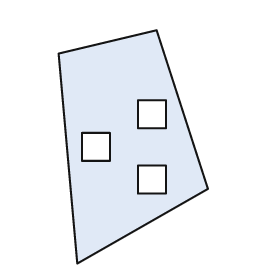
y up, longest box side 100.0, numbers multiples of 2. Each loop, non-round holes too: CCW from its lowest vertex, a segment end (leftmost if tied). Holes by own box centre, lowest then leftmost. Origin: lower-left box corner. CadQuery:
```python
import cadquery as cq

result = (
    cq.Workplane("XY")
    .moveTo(8.0, 0.0)
    .lineTo(64.0, 32.0)
    .lineTo(42.0, 100.0)
    .lineTo(0.0, 90.0)
    .close()
    .moveTo(34.0, 30.0)
    .lineTo(46.0, 30.0)
    .lineTo(46.0, 42.0)
    .lineTo(34.0, 42.0)
    .close()
    .moveTo(10.0, 44.0)
    .lineTo(22.0, 44.0)
    .lineTo(22.0, 56.0)
    .lineTo(10.0, 56.0)
    .close()
    .moveTo(34.0, 58.0)
    .lineTo(46.0, 58.0)
    .lineTo(46.0, 70.0)
    .lineTo(34.0, 70.0)
    .close()
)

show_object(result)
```